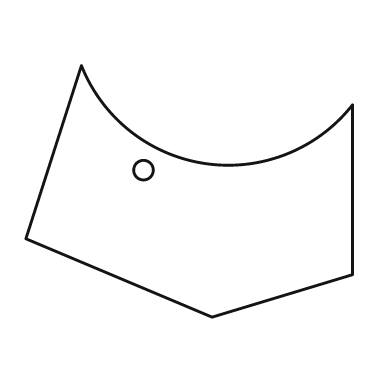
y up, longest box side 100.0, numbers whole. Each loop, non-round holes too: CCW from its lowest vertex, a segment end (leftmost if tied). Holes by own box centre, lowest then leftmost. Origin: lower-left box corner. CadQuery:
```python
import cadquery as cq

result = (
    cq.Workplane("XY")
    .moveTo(57.0, 0.0)
    .lineTo(100.0, 13.0)
    .lineTo(100.0, 65.0)
    .threePointArc((55.0, 47.0), (17.0, 77.0))
    .lineTo(0.0, 24.0)
    .close()
    .moveTo(36.0, 45.0)
    .circle(3.0)
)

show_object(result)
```